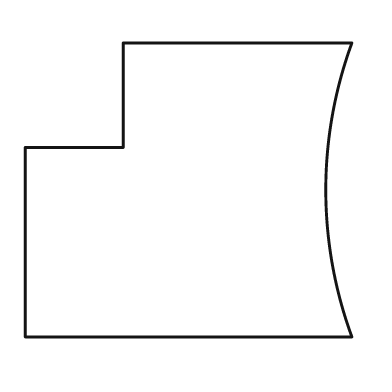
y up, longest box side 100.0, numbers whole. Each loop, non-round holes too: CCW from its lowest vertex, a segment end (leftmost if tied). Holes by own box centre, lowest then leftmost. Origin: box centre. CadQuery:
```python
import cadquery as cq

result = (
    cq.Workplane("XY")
    .moveTo(-50.0, -45.0)
    .lineTo(50.0, -45.0)
    .threePointArc((42.0, 0.0), (50.0, 45.0))
    .lineTo(-20.0, 45.0)
    .lineTo(-20.0, 13.0)
    .lineTo(-50.0, 13.0)
    .close()
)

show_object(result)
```